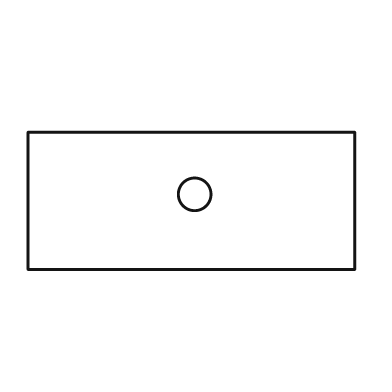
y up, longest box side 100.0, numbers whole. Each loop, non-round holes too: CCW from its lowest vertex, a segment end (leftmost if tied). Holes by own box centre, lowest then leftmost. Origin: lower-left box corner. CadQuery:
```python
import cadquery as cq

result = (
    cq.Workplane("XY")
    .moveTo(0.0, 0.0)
    .lineTo(100.0, 0.0)
    .lineTo(100.0, 42.0)
    .lineTo(0.0, 42.0)
    .close()
    .moveTo(51.0, 23.0)
    .circle(5.0)
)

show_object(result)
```